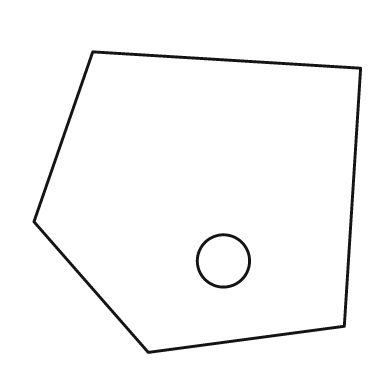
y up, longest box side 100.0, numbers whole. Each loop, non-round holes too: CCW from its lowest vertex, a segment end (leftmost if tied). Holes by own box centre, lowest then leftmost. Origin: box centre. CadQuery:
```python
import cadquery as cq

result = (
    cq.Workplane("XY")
    .moveTo(-15.0, -46.0)
    .lineTo(45.0, -38.0)
    .lineTo(50.0, 41.0)
    .lineTo(-32.0, 46.0)
    .lineTo(-50.0, -6.0)
    .close()
    .moveTo(8.0, -18.0)
    .circle(8.0)
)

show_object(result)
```